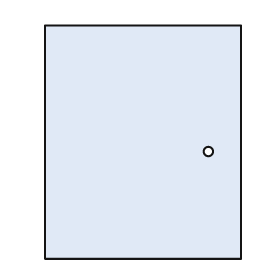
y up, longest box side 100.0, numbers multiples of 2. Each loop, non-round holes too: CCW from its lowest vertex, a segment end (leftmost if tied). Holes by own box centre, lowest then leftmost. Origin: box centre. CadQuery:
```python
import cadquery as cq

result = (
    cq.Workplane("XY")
    .moveTo(-42.0, -50.0)
    .lineTo(42.0, -50.0)
    .lineTo(42.0, 50.0)
    .lineTo(-42.0, 50.0)
    .close()
    .moveTo(28.0, -4.0)
    .circle(2.0)
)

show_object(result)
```